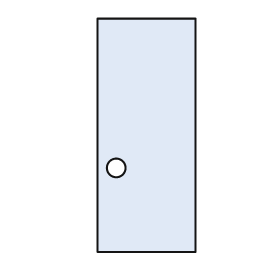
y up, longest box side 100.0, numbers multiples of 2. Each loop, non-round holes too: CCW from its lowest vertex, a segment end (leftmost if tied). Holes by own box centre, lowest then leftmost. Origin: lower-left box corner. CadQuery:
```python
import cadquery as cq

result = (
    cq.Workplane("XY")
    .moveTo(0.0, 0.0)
    .lineTo(42.0, 0.0)
    .lineTo(42.0, 100.0)
    .lineTo(0.0, 100.0)
    .close()
    .moveTo(8.0, 36.0)
    .circle(4.0)
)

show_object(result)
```